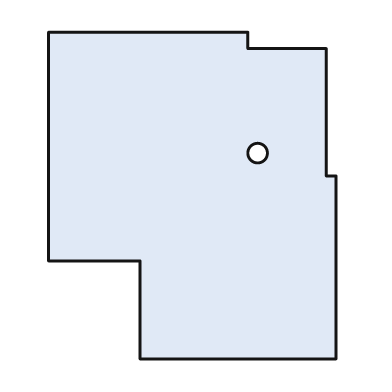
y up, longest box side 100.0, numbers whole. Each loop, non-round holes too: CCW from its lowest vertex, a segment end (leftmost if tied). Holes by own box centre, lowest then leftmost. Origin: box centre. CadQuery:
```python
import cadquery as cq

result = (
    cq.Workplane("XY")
    .moveTo(-16.0, -50.0)
    .lineTo(44.0, -50.0)
    .lineTo(44.0, 6.0)
    .lineTo(41.0, 6.0)
    .lineTo(41.0, 45.0)
    .lineTo(17.0, 45.0)
    .lineTo(17.0, 50.0)
    .lineTo(-44.0, 50.0)
    .lineTo(-44.0, -20.0)
    .lineTo(-16.0, -20.0)
    .close()
    .moveTo(20.0, 13.0)
    .circle(3.0)
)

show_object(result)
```